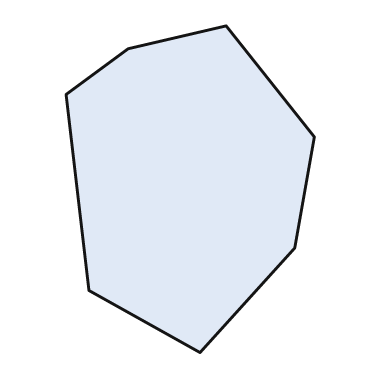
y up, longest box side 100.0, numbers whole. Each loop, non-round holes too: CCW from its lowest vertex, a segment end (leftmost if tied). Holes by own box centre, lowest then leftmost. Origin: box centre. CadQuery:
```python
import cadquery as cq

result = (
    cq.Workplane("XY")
    .moveTo(3.0, -50.0)
    .lineTo(32.0, -18.0)
    .lineTo(38.0, 16.0)
    .lineTo(11.0, 50.0)
    .lineTo(-19.0, 43.0)
    .lineTo(-38.0, 29.0)
    .lineTo(-31.0, -31.0)
    .close()
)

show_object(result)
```